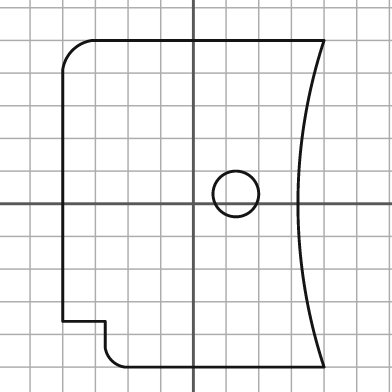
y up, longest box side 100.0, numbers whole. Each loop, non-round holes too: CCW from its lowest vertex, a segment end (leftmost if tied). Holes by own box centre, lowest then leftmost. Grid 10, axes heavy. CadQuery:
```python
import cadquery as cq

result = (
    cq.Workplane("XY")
    .moveTo(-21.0, -50.0)
    .lineTo(40.0, -50.0)
    .threePointArc((32.0, 0.0), (40.0, 50.0))
    .lineTo(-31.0, 50.0)
    .threePointArc((-37.0, 47.0), (-40.0, 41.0))
    .lineTo(-40.0, -36.0)
    .lineTo(-27.0, -36.0)
    .lineTo(-27.0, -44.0)
    .threePointArc((-25.0, -48.0), (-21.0, -50.0))
    .close()
    .moveTo(13.0, 3.0)
    .circle(7.0)
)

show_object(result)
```